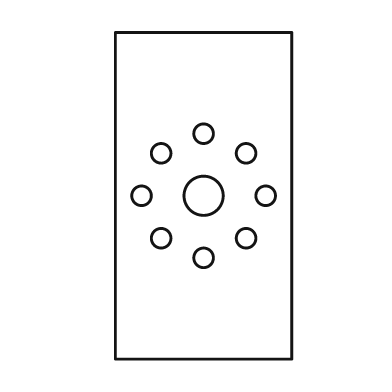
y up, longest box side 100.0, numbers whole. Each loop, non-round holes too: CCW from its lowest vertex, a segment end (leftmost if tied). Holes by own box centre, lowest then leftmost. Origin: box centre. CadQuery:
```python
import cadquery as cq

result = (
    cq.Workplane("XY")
    .moveTo(-27.0, -50.0)
    .lineTo(27.0, -50.0)
    .lineTo(27.0, 50.0)
    .lineTo(-27.0, 50.0)
    .close()
    .moveTo(0.0, -19.0)
    .circle(3.0)
    .moveTo(-13.0, -13.0)
    .circle(3.0)
    .moveTo(13.0, -13.0)
    .circle(3.0)
    .moveTo(-19.0, 0.0)
    .circle(3.0)
    .moveTo(0.0, 0.0)
    .circle(6.0)
    .moveTo(19.0, 0.0)
    .circle(3.0)
    .moveTo(-13.0, 13.0)
    .circle(3.0)
    .moveTo(13.0, 13.0)
    .circle(3.0)
    .moveTo(0.0, 19.0)
    .circle(3.0)
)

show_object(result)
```